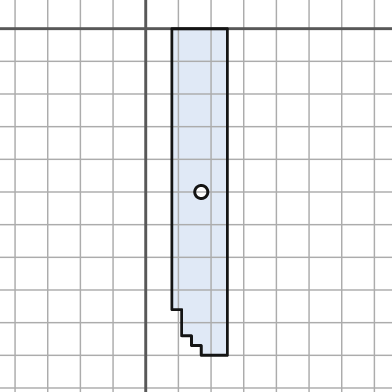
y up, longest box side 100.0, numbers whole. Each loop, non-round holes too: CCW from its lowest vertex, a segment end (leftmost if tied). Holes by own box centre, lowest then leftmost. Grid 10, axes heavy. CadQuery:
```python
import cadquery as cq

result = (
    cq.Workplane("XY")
    .moveTo(17.0, -100.0)
    .lineTo(25.0, -100.0)
    .lineTo(25.0, 0.0)
    .lineTo(8.0, 0.0)
    .lineTo(8.0, -86.0)
    .lineTo(11.0, -86.0)
    .lineTo(11.0, -94.0)
    .lineTo(14.0, -94.0)
    .lineTo(14.0, -97.0)
    .lineTo(17.0, -97.0)
    .close()
    .moveTo(17.0, -50.0)
    .circle(2.0)
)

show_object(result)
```